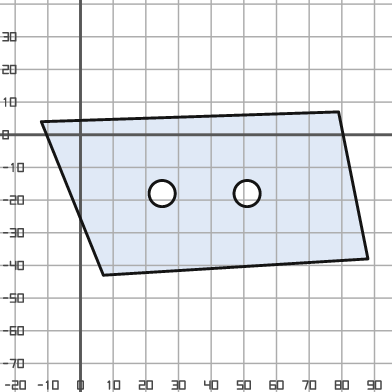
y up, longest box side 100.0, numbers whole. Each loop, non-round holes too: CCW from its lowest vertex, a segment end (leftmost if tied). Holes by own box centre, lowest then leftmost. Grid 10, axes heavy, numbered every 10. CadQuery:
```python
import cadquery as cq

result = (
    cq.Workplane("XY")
    .moveTo(7.0, -43.0)
    .lineTo(88.0, -38.0)
    .lineTo(79.0, 7.0)
    .lineTo(-12.0, 4.0)
    .close()
    .moveTo(25.0, -18.0)
    .circle(4.0)
    .moveTo(51.0, -18.0)
    .circle(4.0)
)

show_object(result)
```